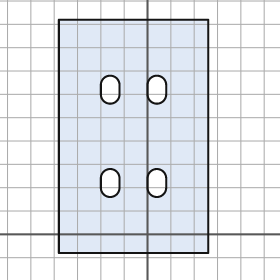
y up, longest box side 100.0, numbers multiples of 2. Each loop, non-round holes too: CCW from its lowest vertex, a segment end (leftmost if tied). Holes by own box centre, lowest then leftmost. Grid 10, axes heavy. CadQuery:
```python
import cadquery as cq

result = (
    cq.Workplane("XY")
    .moveTo(-38.0, -8.0)
    .lineTo(26.0, -8.0)
    .lineTo(26.0, 92.0)
    .lineTo(-38.0, 92.0)
    .close()
    .moveTo(-20.0, 20.0)
    .threePointArc((-16.0, 16.0), (-12.0, 20.0))
    .lineTo(-12.0, 24.0)
    .threePointArc((-16.0, 28.0), (-20.0, 24.0))
    .close()
    .moveTo(0.0, 20.0)
    .threePointArc((4.0, 16.0), (8.0, 20.0))
    .lineTo(8.0, 24.0)
    .threePointArc((4.0, 28.0), (0.0, 24.0))
    .close()
    .moveTo(-20.0, 60.0)
    .threePointArc((-16.0, 56.0), (-12.0, 60.0))
    .lineTo(-12.0, 64.0)
    .threePointArc((-16.0, 68.0), (-20.0, 64.0))
    .close()
    .moveTo(0.0, 60.0)
    .threePointArc((4.0, 56.0), (8.0, 60.0))
    .lineTo(8.0, 64.0)
    .threePointArc((4.0, 68.0), (0.0, 64.0))
    .close()
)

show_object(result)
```